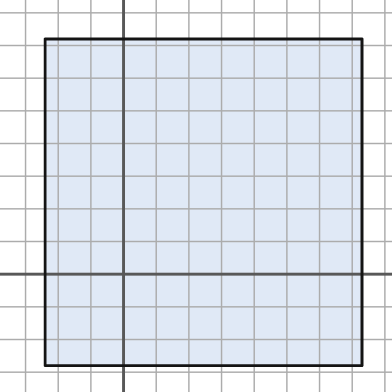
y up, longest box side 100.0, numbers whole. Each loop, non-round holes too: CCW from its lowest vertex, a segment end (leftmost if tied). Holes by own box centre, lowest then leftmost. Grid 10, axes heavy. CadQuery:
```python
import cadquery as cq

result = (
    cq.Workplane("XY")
    .moveTo(-24.0, -28.0)
    .lineTo(73.0, -28.0)
    .lineTo(73.0, 72.0)
    .lineTo(-24.0, 72.0)
    .close()
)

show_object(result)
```